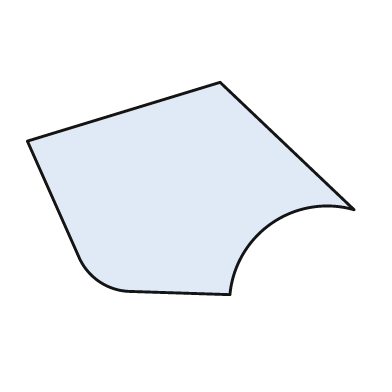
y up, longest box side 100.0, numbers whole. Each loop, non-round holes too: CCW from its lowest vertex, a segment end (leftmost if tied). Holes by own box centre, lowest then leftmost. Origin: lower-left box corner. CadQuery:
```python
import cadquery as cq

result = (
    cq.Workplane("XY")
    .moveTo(62.0, 0.0)
    .threePointArc((75.0, 22.0), (100.0, 26.0))
    .lineTo(59.0, 65.0)
    .lineTo(0.0, 47.0)
    .lineTo(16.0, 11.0)
    .threePointArc((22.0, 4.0), (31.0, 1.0))
    .close()
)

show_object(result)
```